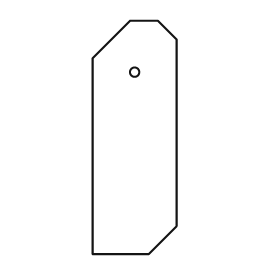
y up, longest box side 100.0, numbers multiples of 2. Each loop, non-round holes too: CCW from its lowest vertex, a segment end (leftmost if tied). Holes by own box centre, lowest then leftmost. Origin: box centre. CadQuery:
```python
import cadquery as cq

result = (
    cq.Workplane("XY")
    .moveTo(-18.0, -50.0)
    .lineTo(6.0, -50.0)
    .lineTo(18.0, -38.0)
    .lineTo(18.0, 42.0)
    .lineTo(10.0, 50.0)
    .lineTo(-2.0, 50.0)
    .lineTo(-18.0, 34.0)
    .close()
    .moveTo(0.0, 28.0)
    .circle(2.0)
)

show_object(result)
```